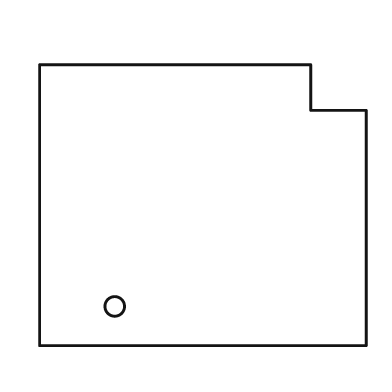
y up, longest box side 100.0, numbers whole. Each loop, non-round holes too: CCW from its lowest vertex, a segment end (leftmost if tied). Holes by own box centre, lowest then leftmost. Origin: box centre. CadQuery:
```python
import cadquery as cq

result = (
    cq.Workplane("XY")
    .moveTo(-50.0, -43.0)
    .lineTo(50.0, -43.0)
    .lineTo(50.0, 29.0)
    .lineTo(33.0, 29.0)
    .lineTo(33.0, 43.0)
    .lineTo(-50.0, 43.0)
    .close()
    .moveTo(-27.0, -31.0)
    .circle(3.0)
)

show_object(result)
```